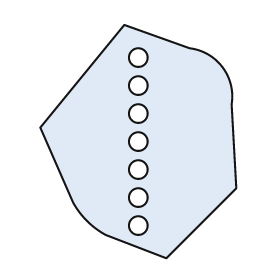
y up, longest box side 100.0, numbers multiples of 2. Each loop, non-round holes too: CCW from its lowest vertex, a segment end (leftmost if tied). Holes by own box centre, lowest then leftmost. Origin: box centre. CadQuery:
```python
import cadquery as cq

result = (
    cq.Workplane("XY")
    .moveTo(12.0, -50.0)
    .lineTo(42.0, -20.0)
    .lineTo(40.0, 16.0)
    .threePointArc((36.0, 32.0), (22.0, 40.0))
    .lineTo(-6.0, 50.0)
    .lineTo(-42.0, 6.0)
    .lineTo(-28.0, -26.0)
    .threePointArc((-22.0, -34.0), (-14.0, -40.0))
    .close()
    .moveTo(0.0, -36.0)
    .circle(4.0)
    .moveTo(0.0, -24.0)
    .circle(4.0)
    .moveTo(0.0, -12.0)
    .circle(4.0)
    .moveTo(0.0, 0.0)
    .circle(4.0)
    .moveTo(0.0, 12.0)
    .circle(4.0)
    .moveTo(0.0, 24.0)
    .circle(4.0)
    .moveTo(0.0, 36.0)
    .circle(4.0)
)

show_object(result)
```